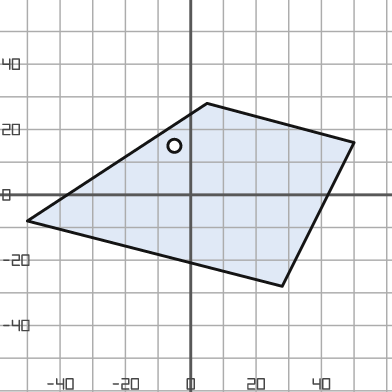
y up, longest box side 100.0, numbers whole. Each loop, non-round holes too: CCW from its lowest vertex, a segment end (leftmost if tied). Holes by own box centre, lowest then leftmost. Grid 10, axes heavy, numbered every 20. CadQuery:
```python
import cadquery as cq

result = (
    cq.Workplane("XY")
    .moveTo(28.0, -28.0)
    .lineTo(50.0, 16.0)
    .lineTo(5.0, 28.0)
    .lineTo(-50.0, -8.0)
    .close()
    .moveTo(-5.0, 15.0)
    .circle(2.0)
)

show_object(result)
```